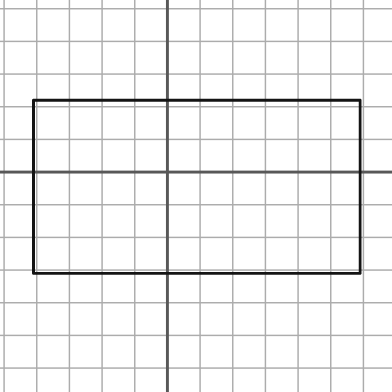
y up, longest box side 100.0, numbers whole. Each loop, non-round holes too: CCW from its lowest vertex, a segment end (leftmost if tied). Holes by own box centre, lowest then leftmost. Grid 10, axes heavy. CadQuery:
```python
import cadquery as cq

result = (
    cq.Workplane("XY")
    .moveTo(-41.0, -31.0)
    .lineTo(59.0, -31.0)
    .lineTo(59.0, 22.0)
    .lineTo(-41.0, 22.0)
    .close()
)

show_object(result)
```